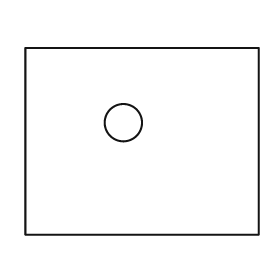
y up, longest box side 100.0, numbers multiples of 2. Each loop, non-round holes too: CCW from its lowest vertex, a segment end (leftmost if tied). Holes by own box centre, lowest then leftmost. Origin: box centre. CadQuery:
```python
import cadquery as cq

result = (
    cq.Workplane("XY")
    .moveTo(-50.0, -40.0)
    .lineTo(50.0, -40.0)
    .lineTo(50.0, 40.0)
    .lineTo(-50.0, 40.0)
    .close()
    .moveTo(-8.0, 8.0)
    .circle(8.0)
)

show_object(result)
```